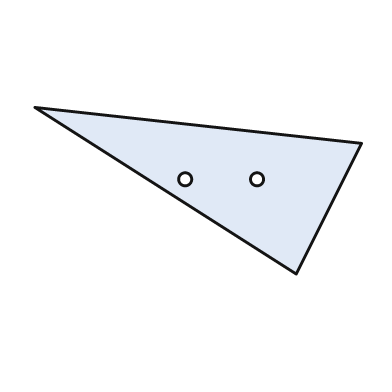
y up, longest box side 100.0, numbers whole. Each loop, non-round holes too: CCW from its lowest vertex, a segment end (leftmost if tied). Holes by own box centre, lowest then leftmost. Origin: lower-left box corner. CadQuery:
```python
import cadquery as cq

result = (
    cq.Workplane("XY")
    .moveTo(80.0, 0.0)
    .lineTo(100.0, 40.0)
    .lineTo(0.0, 51.0)
    .close()
    .moveTo(46.0, 29.0)
    .circle(2.0)
    .moveTo(68.0, 29.0)
    .circle(2.0)
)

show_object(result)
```